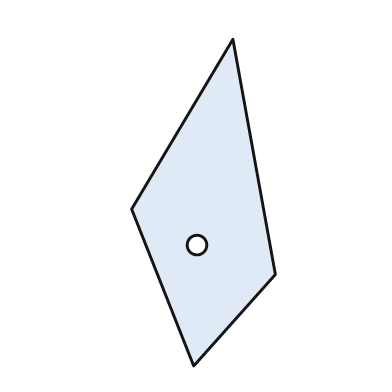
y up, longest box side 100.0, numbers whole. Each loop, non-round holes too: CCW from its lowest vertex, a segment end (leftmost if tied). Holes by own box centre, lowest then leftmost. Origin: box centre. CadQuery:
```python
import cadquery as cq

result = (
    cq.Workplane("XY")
    .moveTo(-3.0, -50.0)
    .lineTo(22.0, -22.0)
    .lineTo(9.0, 50.0)
    .lineTo(-22.0, -2.0)
    .close()
    .moveTo(-2.0, -13.0)
    .circle(3.0)
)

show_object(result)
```